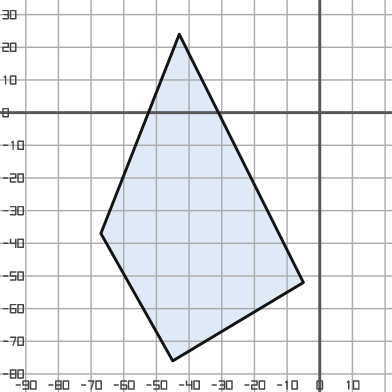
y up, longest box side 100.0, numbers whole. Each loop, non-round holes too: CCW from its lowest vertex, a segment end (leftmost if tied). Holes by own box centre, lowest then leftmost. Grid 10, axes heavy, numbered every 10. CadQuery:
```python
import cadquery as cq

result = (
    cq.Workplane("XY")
    .moveTo(-45.0, -76.0)
    .lineTo(-5.0, -52.0)
    .lineTo(-43.0, 24.0)
    .lineTo(-67.0, -37.0)
    .close()
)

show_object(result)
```